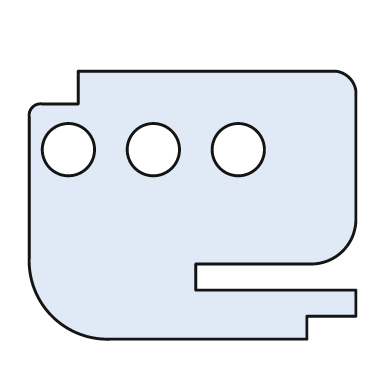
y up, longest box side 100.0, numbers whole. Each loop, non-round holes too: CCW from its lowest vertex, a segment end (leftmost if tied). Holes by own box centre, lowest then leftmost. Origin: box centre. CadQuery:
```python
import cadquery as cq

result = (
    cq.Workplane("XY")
    .moveTo(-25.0, -41.0)
    .lineTo(35.0, -41.0)
    .lineTo(35.0, -34.0)
    .lineTo(50.0, -34.0)
    .lineTo(50.0, -26.0)
    .lineTo(1.0, -26.0)
    .lineTo(1.0, -18.0)
    .lineTo(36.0, -18.0)
    .threePointArc((46.0, -14.0), (50.0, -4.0))
    .lineTo(50.0, 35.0)
    .threePointArc((48.0, 39.0), (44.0, 41.0))
    .lineTo(-35.0, 41.0)
    .lineTo(-35.0, 31.0)
    .lineTo(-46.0, 31.0)
    .threePointArc((-49.0, 30.0), (-50.0, 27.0))
    .lineTo(-50.0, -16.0)
    .threePointArc((-43.0, -34.0), (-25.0, -41.0))
    .close()
    .moveTo(-38.0, 17.0)
    .circle(8.0)
    .moveTo(-12.0, 17.0)
    .circle(8.0)
    .moveTo(14.0, 17.0)
    .circle(8.0)
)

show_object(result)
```